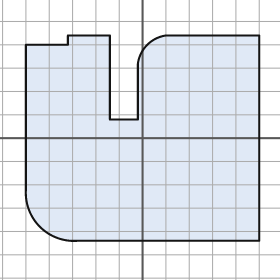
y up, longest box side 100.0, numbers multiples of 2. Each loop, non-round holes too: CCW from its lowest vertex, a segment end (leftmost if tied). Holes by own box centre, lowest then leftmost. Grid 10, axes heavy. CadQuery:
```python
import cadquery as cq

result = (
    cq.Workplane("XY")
    .moveTo(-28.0, -44.0)
    .lineTo(50.0, -44.0)
    .lineTo(50.0, 44.0)
    .lineTo(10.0, 44.0)
    .threePointArc((2.0, 40.0), (-2.0, 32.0))
    .lineTo(-2.0, 8.0)
    .lineTo(-14.0, 8.0)
    .lineTo(-14.0, 44.0)
    .lineTo(-32.0, 44.0)
    .lineTo(-32.0, 40.0)
    .lineTo(-50.0, 40.0)
    .lineTo(-50.0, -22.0)
    .threePointArc((-44.0, -38.0), (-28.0, -44.0))
    .close()
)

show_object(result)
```